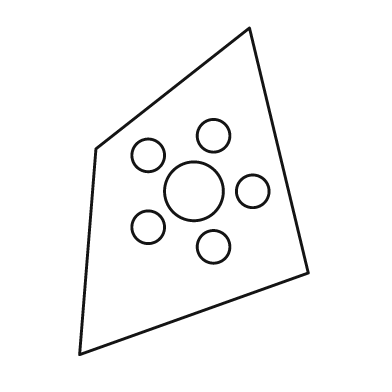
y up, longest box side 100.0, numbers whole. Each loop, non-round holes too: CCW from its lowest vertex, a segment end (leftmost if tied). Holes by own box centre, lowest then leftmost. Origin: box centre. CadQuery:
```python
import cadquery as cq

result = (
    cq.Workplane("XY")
    .moveTo(-35.0, -50.0)
    .lineTo(35.0, -25.0)
    .lineTo(17.0, 50.0)
    .lineTo(-30.0, 13.0)
    .close()
    .moveTo(6.0, -17.0)
    .circle(5.0)
    .moveTo(-14.0, -11.0)
    .circle(5.0)
    .moveTo(0.0, 0.0)
    .circle(9.0)
    .moveTo(18.0, 0.0)
    .circle(5.0)
    .moveTo(-14.0, 11.0)
    .circle(5.0)
    .moveTo(6.0, 17.0)
    .circle(5.0)
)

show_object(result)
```